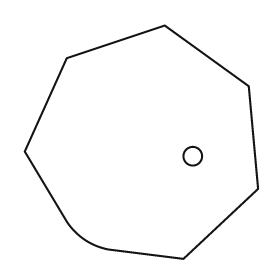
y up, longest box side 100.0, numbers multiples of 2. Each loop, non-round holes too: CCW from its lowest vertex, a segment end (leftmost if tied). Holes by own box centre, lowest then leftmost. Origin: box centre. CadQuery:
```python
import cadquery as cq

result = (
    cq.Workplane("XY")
    .moveTo(18.0, -50.0)
    .lineTo(50.0, -20.0)
    .lineTo(46.0, 24.0)
    .lineTo(10.0, 50.0)
    .lineTo(-32.0, 36.0)
    .lineTo(-50.0, -4.0)
    .lineTo(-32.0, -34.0)
    .threePointArc((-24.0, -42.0), (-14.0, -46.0))
    .close()
    .moveTo(22.0, -6.0)
    .circle(4.0)
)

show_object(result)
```